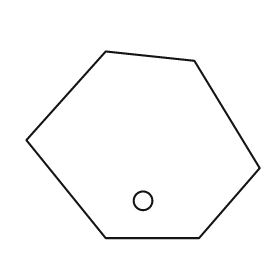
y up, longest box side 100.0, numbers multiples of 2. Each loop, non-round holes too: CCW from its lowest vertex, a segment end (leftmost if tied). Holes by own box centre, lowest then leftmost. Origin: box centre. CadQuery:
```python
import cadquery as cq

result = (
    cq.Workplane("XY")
    .moveTo(-16.0, -40.0)
    .lineTo(24.0, -40.0)
    .lineTo(50.0, -10.0)
    .lineTo(22.0, 36.0)
    .lineTo(-16.0, 40.0)
    .lineTo(-50.0, 2.0)
    .close()
    .moveTo(0.0, -24.0)
    .circle(4.0)
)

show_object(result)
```